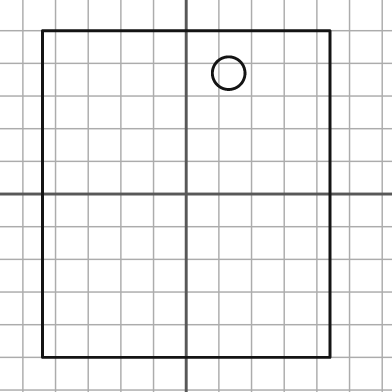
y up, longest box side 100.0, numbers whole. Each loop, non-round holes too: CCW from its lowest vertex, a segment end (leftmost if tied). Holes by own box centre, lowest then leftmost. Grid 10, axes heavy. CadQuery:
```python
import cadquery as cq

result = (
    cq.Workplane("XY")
    .moveTo(-44.0, -50.0)
    .lineTo(44.0, -50.0)
    .lineTo(44.0, 50.0)
    .lineTo(-44.0, 50.0)
    .close()
    .moveTo(13.0, 37.0)
    .circle(5.0)
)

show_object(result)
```